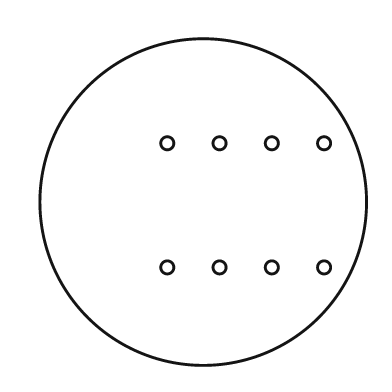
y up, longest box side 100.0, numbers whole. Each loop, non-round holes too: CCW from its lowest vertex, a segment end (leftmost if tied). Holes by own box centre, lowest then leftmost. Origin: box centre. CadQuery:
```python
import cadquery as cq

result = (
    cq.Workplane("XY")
    .moveTo(0.0, 0.0)
    .circle(50.0)
    .moveTo(-11.0, -20.0)
    .circle(2.0)
    .moveTo(5.0, -20.0)
    .circle(2.0)
    .moveTo(21.0, -20.0)
    .circle(2.0)
    .moveTo(37.0, -20.0)
    .circle(2.0)
    .moveTo(-11.0, 18.0)
    .circle(2.0)
    .moveTo(5.0, 18.0)
    .circle(2.0)
    .moveTo(21.0, 18.0)
    .circle(2.0)
    .moveTo(37.0, 18.0)
    .circle(2.0)
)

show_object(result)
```